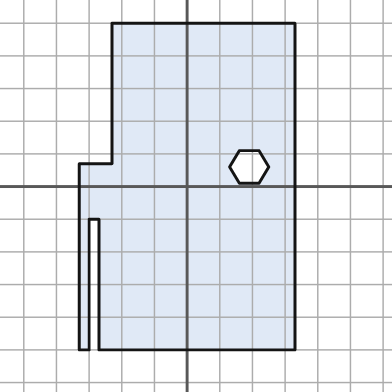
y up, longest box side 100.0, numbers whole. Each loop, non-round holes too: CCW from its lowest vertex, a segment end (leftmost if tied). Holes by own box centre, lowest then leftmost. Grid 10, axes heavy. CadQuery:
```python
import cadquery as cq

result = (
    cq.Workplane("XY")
    .moveTo(-33.0, -50.0)
    .lineTo(-30.0, -50.0)
    .lineTo(-30.0, -10.0)
    .lineTo(-27.0, -10.0)
    .lineTo(-27.0, -50.0)
    .lineTo(33.0, -50.0)
    .lineTo(33.0, 50.0)
    .lineTo(-23.0, 50.0)
    .lineTo(-23.0, 7.0)
    .lineTo(-33.0, 7.0)
    .close()
    .moveTo(16.0, 1.0)
    .lineTo(22.0, 1.0)
    .lineTo(25.0, 6.0)
    .lineTo(22.0, 11.0)
    .lineTo(16.0, 11.0)
    .lineTo(13.0, 6.0)
    .close()
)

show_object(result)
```